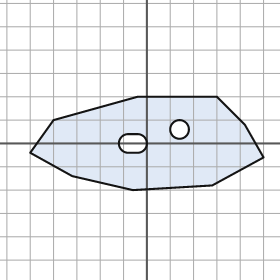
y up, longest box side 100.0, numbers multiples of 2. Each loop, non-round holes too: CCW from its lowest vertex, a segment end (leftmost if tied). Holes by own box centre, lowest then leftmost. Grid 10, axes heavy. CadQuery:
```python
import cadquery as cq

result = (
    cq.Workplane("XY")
    .moveTo(-6.0, -20.0)
    .lineTo(28.0, -18.0)
    .lineTo(50.0, -6.0)
    .lineTo(42.0, 8.0)
    .lineTo(30.0, 20.0)
    .lineTo(-4.0, 20.0)
    .lineTo(-40.0, 10.0)
    .lineTo(-50.0, -4.0)
    .lineTo(-32.0, -14.0)
    .close()
    .moveTo(-8.0, -4.0)
    .lineTo(-4.0, -4.0)
    .threePointArc((0.0, 0.0), (-4.0, 4.0))
    .lineTo(-8.0, 4.0)
    .threePointArc((-12.0, 0.0), (-8.0, -4.0))
    .close()
    .moveTo(14.0, 6.0)
    .circle(4.0)
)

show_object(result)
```